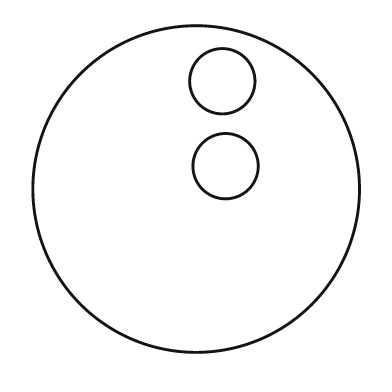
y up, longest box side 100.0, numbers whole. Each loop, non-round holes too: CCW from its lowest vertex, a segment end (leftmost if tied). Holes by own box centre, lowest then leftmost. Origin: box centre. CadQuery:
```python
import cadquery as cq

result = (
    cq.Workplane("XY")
    .moveTo(0.0, 0.0)
    .circle(50.0)
    .moveTo(9.0, 7.0)
    .circle(10.0)
    .moveTo(8.0, 33.0)
    .circle(10.0)
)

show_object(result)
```